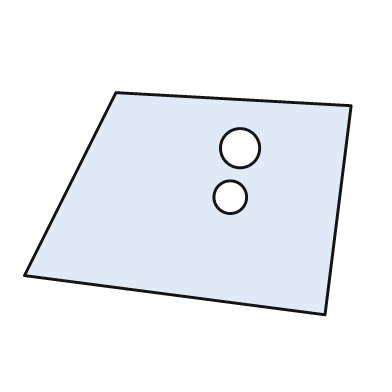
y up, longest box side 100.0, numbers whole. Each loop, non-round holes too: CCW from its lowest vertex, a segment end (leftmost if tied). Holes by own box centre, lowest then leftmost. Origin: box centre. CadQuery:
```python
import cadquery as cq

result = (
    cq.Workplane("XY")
    .moveTo(42.0, -34.0)
    .lineTo(50.0, 30.0)
    .lineTo(-22.0, 34.0)
    .lineTo(-50.0, -22.0)
    .close()
    .moveTo(13.0, 2.0)
    .circle(5.0)
    .moveTo(16.0, 17.0)
    .circle(6.0)
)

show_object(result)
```